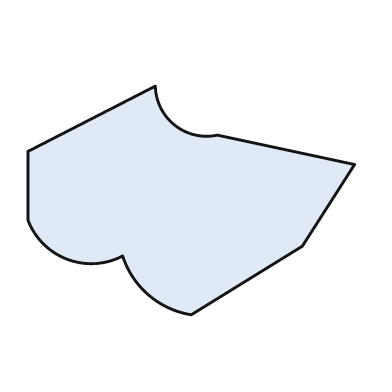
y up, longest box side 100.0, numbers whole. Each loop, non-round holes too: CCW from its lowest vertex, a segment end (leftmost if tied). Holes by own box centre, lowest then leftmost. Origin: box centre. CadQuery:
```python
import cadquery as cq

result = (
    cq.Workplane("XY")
    .moveTo(0.0, -35.0)
    .lineTo(34.0, -14.0)
    .lineTo(50.0, 11.0)
    .lineTo(8.0, 20.0)
    .threePointArc((-5.0, 23.0), (-11.0, 35.0))
    .lineTo(-50.0, 15.0)
    .lineTo(-50.0, -6.0)
    .threePointArc((-38.0, -18.0), (-21.0, -17.0))
    .threePointArc((-13.0, -29.0), (0.0, -35.0))
    .close()
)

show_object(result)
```